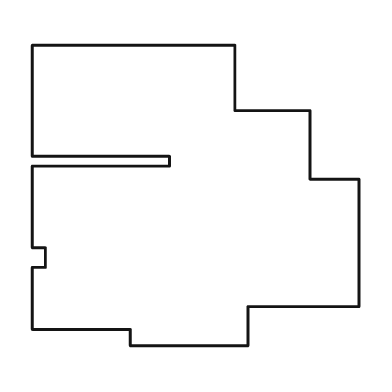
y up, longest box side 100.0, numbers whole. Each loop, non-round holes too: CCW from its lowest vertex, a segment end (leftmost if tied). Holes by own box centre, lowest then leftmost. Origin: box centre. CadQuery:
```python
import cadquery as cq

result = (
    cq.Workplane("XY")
    .moveTo(-20.0, -46.0)
    .lineTo(16.0, -46.0)
    .lineTo(16.0, -34.0)
    .lineTo(50.0, -34.0)
    .lineTo(50.0, 5.0)
    .lineTo(35.0, 5.0)
    .lineTo(35.0, 26.0)
    .lineTo(12.0, 26.0)
    .lineTo(12.0, 46.0)
    .lineTo(-50.0, 46.0)
    .lineTo(-50.0, 12.0)
    .lineTo(-8.0, 12.0)
    .lineTo(-8.0, 9.0)
    .lineTo(-50.0, 9.0)
    .lineTo(-50.0, -16.0)
    .lineTo(-46.0, -16.0)
    .lineTo(-46.0, -22.0)
    .lineTo(-50.0, -22.0)
    .lineTo(-50.0, -41.0)
    .lineTo(-20.0, -41.0)
    .close()
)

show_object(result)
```